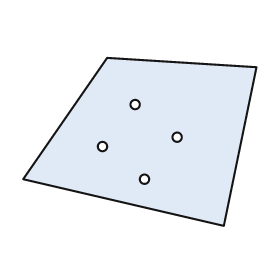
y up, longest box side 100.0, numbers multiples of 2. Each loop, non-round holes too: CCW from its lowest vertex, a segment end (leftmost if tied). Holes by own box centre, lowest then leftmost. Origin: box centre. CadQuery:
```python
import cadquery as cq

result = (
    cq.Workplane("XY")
    .moveTo(36.0, -36.0)
    .lineTo(50.0, 32.0)
    .lineTo(-14.0, 36.0)
    .lineTo(-50.0, -16.0)
    .close()
    .moveTo(2.0, -16.0)
    .circle(2.0)
    .moveTo(-16.0, -2.0)
    .circle(2.0)
    .moveTo(16.0, 2.0)
    .circle(2.0)
    .moveTo(-2.0, 16.0)
    .circle(2.0)
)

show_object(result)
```